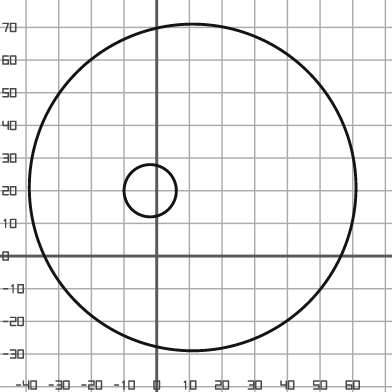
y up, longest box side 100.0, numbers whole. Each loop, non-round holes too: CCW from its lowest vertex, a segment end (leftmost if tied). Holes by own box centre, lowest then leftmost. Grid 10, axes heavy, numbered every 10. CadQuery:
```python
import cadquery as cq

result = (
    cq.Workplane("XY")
    .moveTo(11.0, 21.0)
    .circle(50.0)
    .moveTo(-2.0, 20.0)
    .circle(8.0)
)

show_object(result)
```